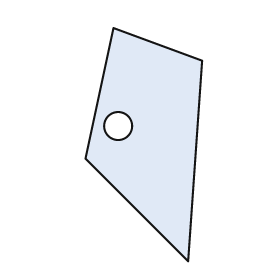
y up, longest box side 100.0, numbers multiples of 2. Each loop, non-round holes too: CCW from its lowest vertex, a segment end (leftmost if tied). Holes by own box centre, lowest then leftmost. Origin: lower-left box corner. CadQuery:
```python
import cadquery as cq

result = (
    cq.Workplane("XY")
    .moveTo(44.0, 0.0)
    .lineTo(50.0, 86.0)
    .lineTo(12.0, 100.0)
    .lineTo(0.0, 44.0)
    .close()
    .moveTo(14.0, 58.0)
    .circle(6.0)
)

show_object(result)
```